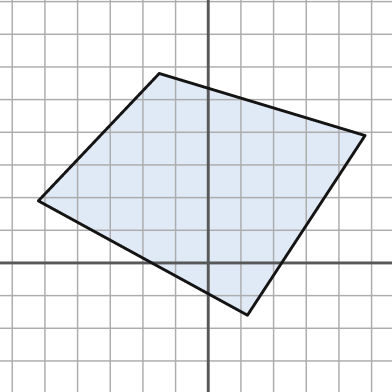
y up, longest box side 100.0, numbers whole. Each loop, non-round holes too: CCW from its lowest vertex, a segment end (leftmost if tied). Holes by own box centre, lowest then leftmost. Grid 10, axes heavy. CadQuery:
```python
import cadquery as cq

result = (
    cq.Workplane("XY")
    .moveTo(12.0, -16.0)
    .lineTo(48.0, 39.0)
    .lineTo(-15.0, 58.0)
    .lineTo(-52.0, 19.0)
    .close()
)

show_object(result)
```